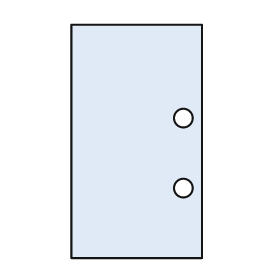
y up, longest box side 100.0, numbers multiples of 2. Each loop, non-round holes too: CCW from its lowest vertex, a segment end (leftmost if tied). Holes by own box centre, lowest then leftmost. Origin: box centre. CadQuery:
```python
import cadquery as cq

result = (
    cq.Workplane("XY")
    .moveTo(-28.0, -50.0)
    .lineTo(28.0, -50.0)
    .lineTo(28.0, 50.0)
    .lineTo(-28.0, 50.0)
    .close()
    .moveTo(20.0, -20.0)
    .circle(4.0)
    .moveTo(20.0, 10.0)
    .circle(4.0)
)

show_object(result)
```